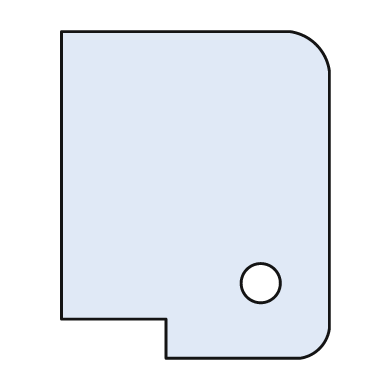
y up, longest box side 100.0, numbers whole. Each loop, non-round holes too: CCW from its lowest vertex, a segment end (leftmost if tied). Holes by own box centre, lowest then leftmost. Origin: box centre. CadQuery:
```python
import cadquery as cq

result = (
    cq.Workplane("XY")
    .moveTo(-9.0, -50.0)
    .lineTo(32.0, -50.0)
    .threePointArc((38.0, -47.0), (41.0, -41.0))
    .lineTo(41.0, 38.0)
    .threePointArc((37.0, 46.0), (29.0, 50.0))
    .lineTo(-41.0, 50.0)
    .lineTo(-41.0, -38.0)
    .lineTo(-9.0, -38.0)
    .close()
    .moveTo(20.0, -27.0)
    .circle(6.0)
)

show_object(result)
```